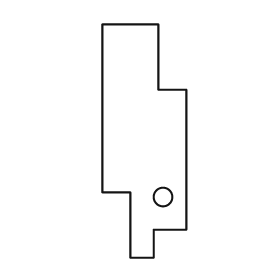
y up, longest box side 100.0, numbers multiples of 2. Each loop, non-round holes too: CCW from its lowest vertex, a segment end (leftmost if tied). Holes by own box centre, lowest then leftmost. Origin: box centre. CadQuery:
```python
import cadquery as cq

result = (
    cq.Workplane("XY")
    .moveTo(-6.0, -50.0)
    .lineTo(4.0, -50.0)
    .lineTo(4.0, -38.0)
    .lineTo(18.0, -38.0)
    .lineTo(18.0, 22.0)
    .lineTo(6.0, 22.0)
    .lineTo(6.0, 50.0)
    .lineTo(-18.0, 50.0)
    .lineTo(-18.0, -22.0)
    .lineTo(-6.0, -22.0)
    .close()
    .moveTo(8.0, -24.0)
    .circle(4.0)
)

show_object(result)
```